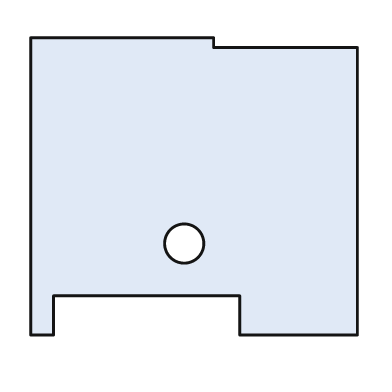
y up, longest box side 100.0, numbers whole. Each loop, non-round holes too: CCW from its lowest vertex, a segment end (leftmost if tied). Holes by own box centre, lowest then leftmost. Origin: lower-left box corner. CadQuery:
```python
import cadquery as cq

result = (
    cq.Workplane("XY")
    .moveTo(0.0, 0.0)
    .lineTo(7.0, 0.0)
    .lineTo(7.0, 12.0)
    .lineTo(64.0, 12.0)
    .lineTo(64.0, 0.0)
    .lineTo(100.0, 0.0)
    .lineTo(100.0, 88.0)
    .lineTo(56.0, 88.0)
    .lineTo(56.0, 91.0)
    .lineTo(0.0, 91.0)
    .close()
    .moveTo(47.0, 28.0)
    .circle(6.0)
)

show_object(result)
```